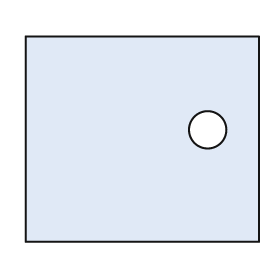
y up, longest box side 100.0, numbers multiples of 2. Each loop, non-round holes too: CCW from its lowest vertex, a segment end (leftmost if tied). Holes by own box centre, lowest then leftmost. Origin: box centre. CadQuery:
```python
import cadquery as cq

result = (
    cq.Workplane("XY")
    .moveTo(-50.0, -44.0)
    .lineTo(50.0, -44.0)
    .lineTo(50.0, 44.0)
    .lineTo(-50.0, 44.0)
    .close()
    .moveTo(28.0, 4.0)
    .circle(8.0)
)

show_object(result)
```